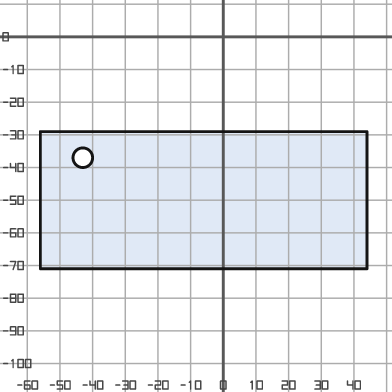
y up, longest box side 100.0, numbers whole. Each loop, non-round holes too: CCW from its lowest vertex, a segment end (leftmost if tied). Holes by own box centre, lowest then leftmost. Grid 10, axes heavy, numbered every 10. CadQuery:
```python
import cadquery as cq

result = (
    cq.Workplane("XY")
    .moveTo(-56.0, -71.0)
    .lineTo(44.0, -71.0)
    .lineTo(44.0, -29.0)
    .lineTo(-56.0, -29.0)
    .close()
    .moveTo(-43.0, -37.0)
    .circle(3.0)
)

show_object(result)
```